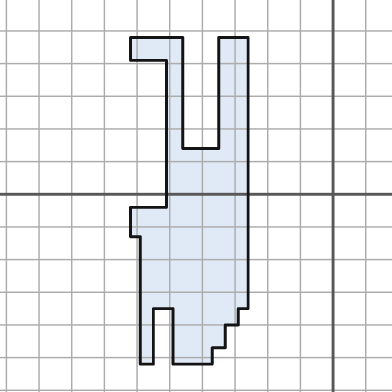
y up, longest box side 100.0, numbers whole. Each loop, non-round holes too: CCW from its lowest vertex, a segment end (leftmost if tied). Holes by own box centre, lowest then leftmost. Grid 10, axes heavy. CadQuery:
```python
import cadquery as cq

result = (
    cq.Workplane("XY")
    .moveTo(-59.0, -52.0)
    .lineTo(-55.0, -52.0)
    .lineTo(-55.0, -35.0)
    .lineTo(-49.0, -35.0)
    .lineTo(-49.0, -52.0)
    .lineTo(-37.0, -52.0)
    .lineTo(-37.0, -47.0)
    .lineTo(-33.0, -47.0)
    .lineTo(-33.0, -40.0)
    .lineTo(-29.0, -40.0)
    .lineTo(-29.0, -35.0)
    .lineTo(-26.0, -35.0)
    .lineTo(-26.0, 48.0)
    .lineTo(-35.0, 48.0)
    .lineTo(-35.0, 14.0)
    .lineTo(-46.0, 14.0)
    .lineTo(-46.0, 48.0)
    .lineTo(-62.0, 48.0)
    .lineTo(-62.0, 41.0)
    .lineTo(-51.0, 41.0)
    .lineTo(-51.0, -4.0)
    .lineTo(-62.0, -4.0)
    .lineTo(-62.0, -13.0)
    .lineTo(-59.0, -13.0)
    .close()
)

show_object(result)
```